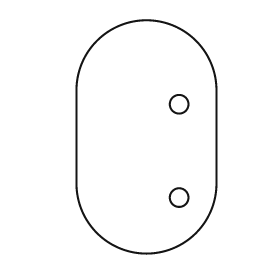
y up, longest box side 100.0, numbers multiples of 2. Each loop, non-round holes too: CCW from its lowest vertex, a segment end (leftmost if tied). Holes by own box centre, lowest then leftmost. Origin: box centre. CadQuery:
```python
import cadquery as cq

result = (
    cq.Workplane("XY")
    .moveTo(-30.0, -20.0)
    .threePointArc((0.0, -50.0), (30.0, -20.0))
    .lineTo(30.0, 20.0)
    .threePointArc((0.0, 50.0), (-30.0, 20.0))
    .close()
    .moveTo(14.0, -26.0)
    .circle(4.0)
    .moveTo(14.0, 14.0)
    .circle(4.0)
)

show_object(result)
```